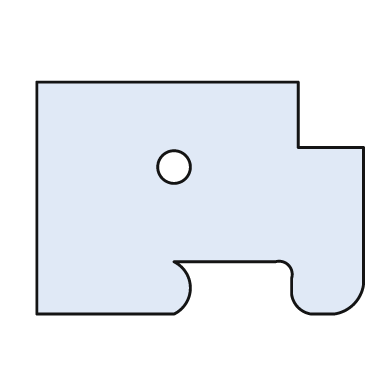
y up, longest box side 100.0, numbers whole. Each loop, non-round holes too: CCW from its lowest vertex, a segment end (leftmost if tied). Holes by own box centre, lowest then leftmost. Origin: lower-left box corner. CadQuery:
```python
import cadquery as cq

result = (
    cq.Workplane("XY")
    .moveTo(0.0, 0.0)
    .lineTo(42.0, 0.0)
    .threePointArc((47.0, 8.0), (42.0, 16.0))
    .lineTo(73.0, 16.0)
    .threePointArc((77.0, 15.0), (78.0, 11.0))
    .lineTo(78.0, 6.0)
    .threePointArc((80.0, 2.0), (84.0, 0.0))
    .lineTo(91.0, 0.0)
    .threePointArc((97.0, 3.0), (100.0, 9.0))
    .lineTo(100.0, 51.0)
    .lineTo(80.0, 51.0)
    .lineTo(80.0, 71.0)
    .lineTo(0.0, 71.0)
    .close()
    .moveTo(42.0, 45.0)
    .circle(5.0)
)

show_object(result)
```